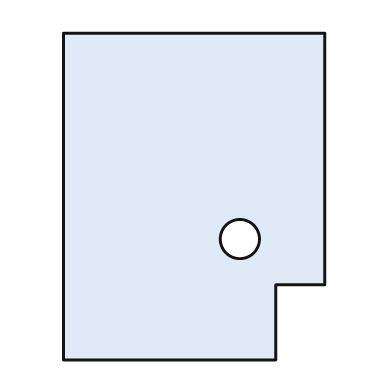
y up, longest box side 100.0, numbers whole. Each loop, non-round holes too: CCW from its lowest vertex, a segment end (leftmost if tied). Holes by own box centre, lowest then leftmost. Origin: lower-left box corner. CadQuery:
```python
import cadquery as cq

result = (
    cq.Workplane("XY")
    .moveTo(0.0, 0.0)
    .lineTo(65.0, 0.0)
    .lineTo(65.0, 23.0)
    .lineTo(80.0, 23.0)
    .lineTo(80.0, 100.0)
    .lineTo(0.0, 100.0)
    .close()
    .moveTo(54.0, 37.0)
    .circle(6.0)
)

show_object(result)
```